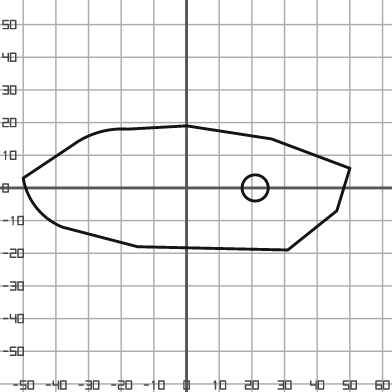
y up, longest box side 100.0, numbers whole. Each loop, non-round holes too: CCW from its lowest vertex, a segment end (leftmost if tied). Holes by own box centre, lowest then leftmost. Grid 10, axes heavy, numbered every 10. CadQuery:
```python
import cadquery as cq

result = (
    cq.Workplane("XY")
    .moveTo(31.0, -19.0)
    .lineTo(46.0, -7.0)
    .lineTo(50.0, 6.0)
    .lineTo(26.0, 15.0)
    .lineTo(0.0, 19.0)
    .lineTo(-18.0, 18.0)
    .threePointArc((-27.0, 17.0), (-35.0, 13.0))
    .lineTo(-50.0, 3.0)
    .threePointArc((-46.0, -6.0), (-38.0, -12.0))
    .lineTo(-15.0, -18.0)
    .close()
    .moveTo(21.0, 0.0)
    .circle(4.0)
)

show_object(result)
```